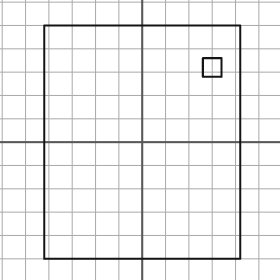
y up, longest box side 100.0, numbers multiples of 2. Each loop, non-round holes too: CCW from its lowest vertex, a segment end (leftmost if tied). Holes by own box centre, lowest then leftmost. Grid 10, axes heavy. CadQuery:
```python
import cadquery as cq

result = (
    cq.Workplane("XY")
    .moveTo(-42.0, -50.0)
    .lineTo(42.0, -50.0)
    .lineTo(42.0, 50.0)
    .lineTo(-42.0, 50.0)
    .close()
    .moveTo(26.0, 28.0)
    .lineTo(34.0, 28.0)
    .lineTo(34.0, 36.0)
    .lineTo(26.0, 36.0)
    .close()
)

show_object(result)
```